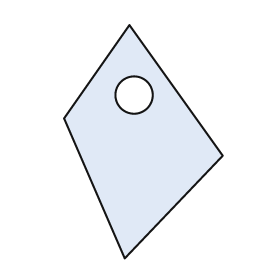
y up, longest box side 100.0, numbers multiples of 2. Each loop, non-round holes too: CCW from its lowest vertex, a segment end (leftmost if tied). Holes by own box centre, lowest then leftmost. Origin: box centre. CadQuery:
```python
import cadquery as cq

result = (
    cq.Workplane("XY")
    .moveTo(-8.0, -50.0)
    .lineTo(34.0, -6.0)
    .lineTo(-6.0, 50.0)
    .lineTo(-34.0, 10.0)
    .close()
    .moveTo(-4.0, 20.0)
    .circle(8.0)
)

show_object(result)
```